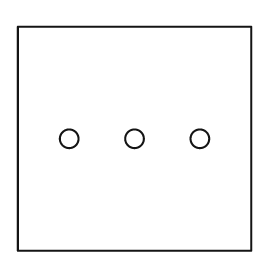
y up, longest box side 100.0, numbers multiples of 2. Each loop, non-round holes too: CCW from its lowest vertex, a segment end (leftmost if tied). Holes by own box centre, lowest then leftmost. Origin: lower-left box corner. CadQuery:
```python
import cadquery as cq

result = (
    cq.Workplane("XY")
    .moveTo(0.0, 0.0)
    .lineTo(100.0, 0.0)
    .lineTo(100.0, 96.0)
    .lineTo(0.0, 96.0)
    .close()
    .moveTo(22.0, 48.0)
    .circle(4.0)
    .moveTo(50.0, 48.0)
    .circle(4.0)
    .moveTo(78.0, 48.0)
    .circle(4.0)
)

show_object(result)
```